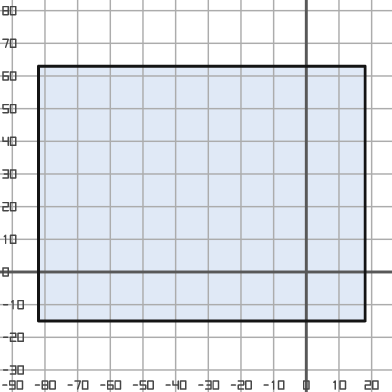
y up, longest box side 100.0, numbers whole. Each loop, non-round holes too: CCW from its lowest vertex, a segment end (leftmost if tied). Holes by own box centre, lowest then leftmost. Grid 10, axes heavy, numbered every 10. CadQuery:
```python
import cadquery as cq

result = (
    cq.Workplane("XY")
    .moveTo(-82.0, -15.0)
    .lineTo(18.0, -15.0)
    .lineTo(18.0, 63.0)
    .lineTo(-82.0, 63.0)
    .close()
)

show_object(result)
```